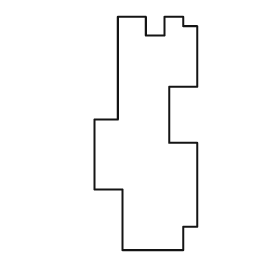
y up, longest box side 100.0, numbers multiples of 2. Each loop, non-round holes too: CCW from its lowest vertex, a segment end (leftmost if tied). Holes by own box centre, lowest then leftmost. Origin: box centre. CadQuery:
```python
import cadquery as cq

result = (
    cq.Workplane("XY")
    .moveTo(-10.0, -50.0)
    .lineTo(16.0, -50.0)
    .lineTo(16.0, -40.0)
    .lineTo(22.0, -40.0)
    .lineTo(22.0, -4.0)
    .lineTo(10.0, -4.0)
    .lineTo(10.0, 20.0)
    .lineTo(22.0, 20.0)
    .lineTo(22.0, 46.0)
    .lineTo(16.0, 46.0)
    .lineTo(16.0, 50.0)
    .lineTo(8.0, 50.0)
    .lineTo(8.0, 42.0)
    .lineTo(0.0, 42.0)
    .lineTo(0.0, 50.0)
    .lineTo(-12.0, 50.0)
    .lineTo(-12.0, 6.0)
    .lineTo(-22.0, 6.0)
    .lineTo(-22.0, -24.0)
    .lineTo(-10.0, -24.0)
    .close()
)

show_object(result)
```